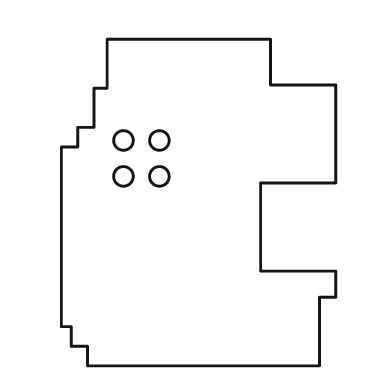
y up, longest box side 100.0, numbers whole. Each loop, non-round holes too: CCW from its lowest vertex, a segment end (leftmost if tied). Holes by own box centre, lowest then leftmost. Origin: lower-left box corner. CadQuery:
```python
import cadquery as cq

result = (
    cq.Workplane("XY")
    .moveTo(8.0, 0.0)
    .lineTo(79.0, 0.0)
    .lineTo(79.0, 21.0)
    .lineTo(84.0, 21.0)
    .lineTo(84.0, 29.0)
    .lineTo(61.0, 29.0)
    .lineTo(61.0, 56.0)
    .lineTo(84.0, 56.0)
    .lineTo(84.0, 86.0)
    .lineTo(64.0, 86.0)
    .lineTo(64.0, 100.0)
    .lineTo(14.0, 100.0)
    .lineTo(14.0, 85.0)
    .lineTo(10.0, 85.0)
    .lineTo(10.0, 73.0)
    .lineTo(5.0, 73.0)
    .lineTo(5.0, 67.0)
    .lineTo(0.0, 67.0)
    .lineTo(0.0, 12.0)
    .lineTo(3.0, 12.0)
    .lineTo(3.0, 6.0)
    .lineTo(8.0, 6.0)
    .close()
    .moveTo(19.0, 58.0)
    .circle(3.0)
    .moveTo(30.0, 58.0)
    .circle(3.0)
    .moveTo(19.0, 69.0)
    .circle(3.0)
    .moveTo(30.0, 69.0)
    .circle(3.0)
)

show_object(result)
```